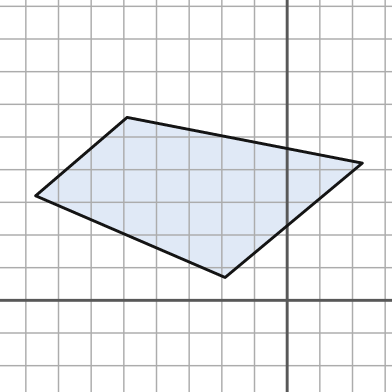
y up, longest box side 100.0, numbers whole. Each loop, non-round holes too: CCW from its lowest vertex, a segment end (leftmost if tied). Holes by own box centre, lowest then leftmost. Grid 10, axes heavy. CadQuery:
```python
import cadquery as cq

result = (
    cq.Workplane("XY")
    .moveTo(-19.0, 7.0)
    .lineTo(23.0, 42.0)
    .lineTo(-49.0, 56.0)
    .lineTo(-77.0, 32.0)
    .close()
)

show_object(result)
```